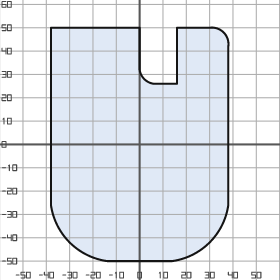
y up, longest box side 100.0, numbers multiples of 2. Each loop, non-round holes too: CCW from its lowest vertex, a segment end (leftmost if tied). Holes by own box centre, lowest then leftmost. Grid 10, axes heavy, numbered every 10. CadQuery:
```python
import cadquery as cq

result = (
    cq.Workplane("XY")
    .moveTo(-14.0, -50.0)
    .lineTo(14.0, -50.0)
    .threePointArc((30.0, -42.0), (38.0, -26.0))
    .lineTo(38.0, 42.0)
    .threePointArc((36.0, 48.0), (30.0, 50.0))
    .lineTo(16.0, 50.0)
    .lineTo(16.0, 26.0)
    .lineTo(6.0, 26.0)
    .threePointArc((2.0, 28.0), (0.0, 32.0))
    .lineTo(0.0, 50.0)
    .lineTo(-38.0, 50.0)
    .lineTo(-38.0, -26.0)
    .threePointArc((-30.0, -42.0), (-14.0, -50.0))
    .close()
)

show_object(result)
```